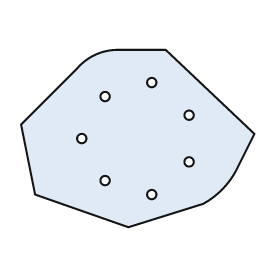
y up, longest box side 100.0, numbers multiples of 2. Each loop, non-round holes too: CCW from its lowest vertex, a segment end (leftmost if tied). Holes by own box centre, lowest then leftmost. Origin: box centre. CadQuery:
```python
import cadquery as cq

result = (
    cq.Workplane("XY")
    .moveTo(-4.0, -38.0)
    .lineTo(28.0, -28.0)
    .threePointArc((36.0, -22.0), (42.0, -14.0))
    .lineTo(50.0, 2.0)
    .lineTo(12.0, 38.0)
    .lineTo(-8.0, 38.0)
    .threePointArc((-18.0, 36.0), (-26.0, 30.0))
    .lineTo(-50.0, 6.0)
    .lineTo(-44.0, -24.0)
    .close()
    .moveTo(6.0, -24.0)
    .circle(2.0)
    .moveTo(-14.0, -18.0)
    .circle(2.0)
    .moveTo(22.0, -10.0)
    .circle(2.0)
    .moveTo(-24.0, 0.0)
    .circle(2.0)
    .moveTo(22.0, 10.0)
    .circle(2.0)
    .moveTo(-14.0, 18.0)
    .circle(2.0)
    .moveTo(6.0, 24.0)
    .circle(2.0)
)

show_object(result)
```